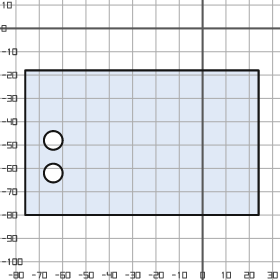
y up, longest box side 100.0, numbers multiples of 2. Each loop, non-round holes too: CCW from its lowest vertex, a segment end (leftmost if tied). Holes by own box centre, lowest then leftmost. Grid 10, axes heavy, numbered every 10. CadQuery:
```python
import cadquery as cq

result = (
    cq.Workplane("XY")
    .moveTo(-76.0, -80.0)
    .lineTo(24.0, -80.0)
    .lineTo(24.0, -18.0)
    .lineTo(-76.0, -18.0)
    .close()
    .moveTo(-64.0, -62.0)
    .circle(4.0)
    .moveTo(-64.0, -48.0)
    .circle(4.0)
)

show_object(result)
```